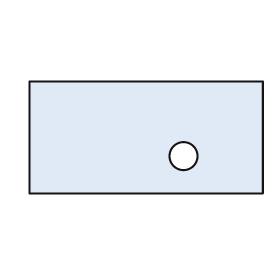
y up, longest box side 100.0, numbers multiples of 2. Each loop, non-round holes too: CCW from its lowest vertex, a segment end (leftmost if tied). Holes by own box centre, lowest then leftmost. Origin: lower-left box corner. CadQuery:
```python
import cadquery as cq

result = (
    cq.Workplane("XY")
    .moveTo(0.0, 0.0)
    .lineTo(100.0, 0.0)
    .lineTo(100.0, 48.0)
    .lineTo(0.0, 48.0)
    .close()
    .moveTo(66.0, 16.0)
    .circle(6.0)
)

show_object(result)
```